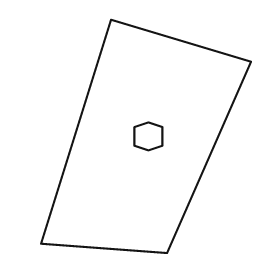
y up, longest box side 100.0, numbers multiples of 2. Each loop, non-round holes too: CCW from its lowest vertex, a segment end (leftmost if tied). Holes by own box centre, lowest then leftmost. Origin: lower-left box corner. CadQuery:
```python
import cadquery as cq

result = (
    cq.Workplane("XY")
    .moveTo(54.0, 0.0)
    .lineTo(90.0, 82.0)
    .lineTo(30.0, 100.0)
    .lineTo(0.0, 4.0)
    .close()
    .moveTo(46.0, 44.0)
    .lineTo(52.0, 46.0)
    .lineTo(52.0, 54.0)
    .lineTo(46.0, 56.0)
    .lineTo(40.0, 54.0)
    .lineTo(40.0, 46.0)
    .close()
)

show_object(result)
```